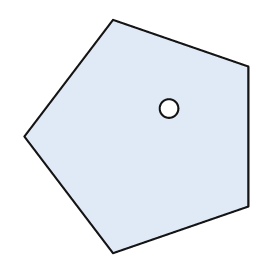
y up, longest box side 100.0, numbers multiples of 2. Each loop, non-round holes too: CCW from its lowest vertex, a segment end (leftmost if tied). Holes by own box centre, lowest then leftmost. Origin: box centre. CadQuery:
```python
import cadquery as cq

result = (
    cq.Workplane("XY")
    .moveTo(-10.0, -50.0)
    .lineTo(48.0, -30.0)
    .lineTo(48.0, 30.0)
    .lineTo(-10.0, 50.0)
    .lineTo(-48.0, 0.0)
    .close()
    .moveTo(14.0, 12.0)
    .circle(4.0)
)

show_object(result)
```